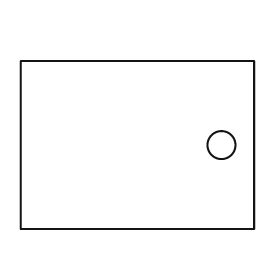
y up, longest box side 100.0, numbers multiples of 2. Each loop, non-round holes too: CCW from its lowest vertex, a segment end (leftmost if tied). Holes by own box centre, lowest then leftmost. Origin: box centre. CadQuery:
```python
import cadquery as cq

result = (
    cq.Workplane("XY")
    .moveTo(-50.0, -36.0)
    .lineTo(50.0, -36.0)
    .lineTo(50.0, 36.0)
    .lineTo(-50.0, 36.0)
    .close()
    .moveTo(36.0, 0.0)
    .circle(6.0)
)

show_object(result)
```